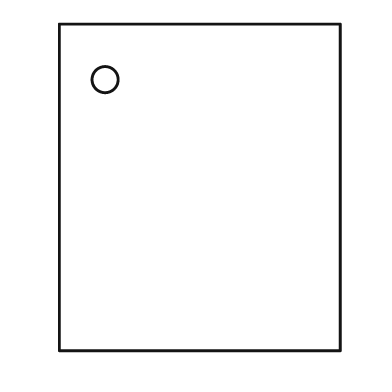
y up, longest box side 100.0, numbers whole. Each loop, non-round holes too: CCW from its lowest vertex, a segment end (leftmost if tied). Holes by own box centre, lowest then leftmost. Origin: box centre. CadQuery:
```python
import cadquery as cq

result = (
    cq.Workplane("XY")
    .moveTo(-43.0, -50.0)
    .lineTo(43.0, -50.0)
    .lineTo(43.0, 50.0)
    .lineTo(-43.0, 50.0)
    .close()
    .moveTo(-29.0, 33.0)
    .circle(4.0)
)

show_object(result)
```